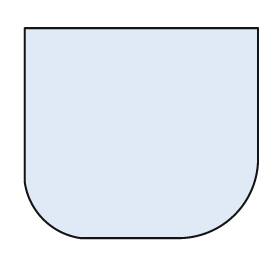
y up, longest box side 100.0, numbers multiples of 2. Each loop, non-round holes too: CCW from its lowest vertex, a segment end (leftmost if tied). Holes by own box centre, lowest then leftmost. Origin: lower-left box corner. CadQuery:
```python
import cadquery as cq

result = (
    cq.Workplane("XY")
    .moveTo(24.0, 0.0)
    .lineTo(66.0, 0.0)
    .threePointArc((90.0, 10.0), (100.0, 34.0))
    .lineTo(100.0, 90.0)
    .lineTo(0.0, 90.0)
    .lineTo(0.0, 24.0)
    .threePointArc((8.0, 8.0), (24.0, 0.0))
    .close()
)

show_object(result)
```